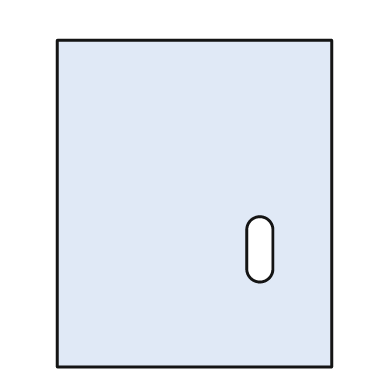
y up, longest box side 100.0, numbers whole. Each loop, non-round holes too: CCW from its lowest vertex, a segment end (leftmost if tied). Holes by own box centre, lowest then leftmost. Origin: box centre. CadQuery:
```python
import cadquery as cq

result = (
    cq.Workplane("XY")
    .moveTo(-42.0, -50.0)
    .lineTo(42.0, -50.0)
    .lineTo(42.0, 50.0)
    .lineTo(-42.0, 50.0)
    .close()
    .moveTo(16.0, -20.0)
    .threePointArc((20.0, -24.0), (24.0, -20.0))
    .lineTo(24.0, -8.0)
    .threePointArc((20.0, -4.0), (16.0, -8.0))
    .close()
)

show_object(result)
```